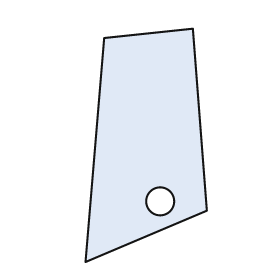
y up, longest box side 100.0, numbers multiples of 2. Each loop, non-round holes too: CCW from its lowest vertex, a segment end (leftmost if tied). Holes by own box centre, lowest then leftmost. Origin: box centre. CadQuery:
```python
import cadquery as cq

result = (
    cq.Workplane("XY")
    .moveTo(-26.0, -50.0)
    .lineTo(26.0, -28.0)
    .lineTo(20.0, 50.0)
    .lineTo(-18.0, 46.0)
    .close()
    .moveTo(6.0, -24.0)
    .circle(6.0)
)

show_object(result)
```